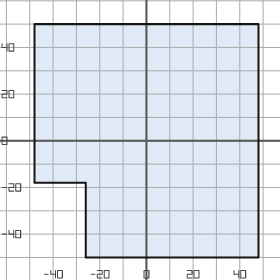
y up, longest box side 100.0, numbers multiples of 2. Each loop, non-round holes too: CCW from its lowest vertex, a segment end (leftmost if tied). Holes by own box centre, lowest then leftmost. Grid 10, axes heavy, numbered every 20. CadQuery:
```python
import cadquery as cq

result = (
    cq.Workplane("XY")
    .moveTo(-26.0, -50.0)
    .lineTo(48.0, -50.0)
    .lineTo(48.0, 50.0)
    .lineTo(-48.0, 50.0)
    .lineTo(-48.0, -18.0)
    .lineTo(-26.0, -18.0)
    .close()
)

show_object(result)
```